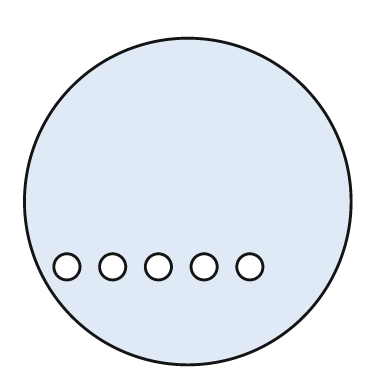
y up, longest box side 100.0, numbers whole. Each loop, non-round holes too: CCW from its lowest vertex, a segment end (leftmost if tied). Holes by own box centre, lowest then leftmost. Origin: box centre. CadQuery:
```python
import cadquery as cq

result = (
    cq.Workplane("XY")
    .moveTo(0.0, 0.0)
    .circle(50.0)
    .moveTo(-37.0, -20.0)
    .circle(4.0)
    .moveTo(-23.0, -20.0)
    .circle(4.0)
    .moveTo(-9.0, -20.0)
    .circle(4.0)
    .moveTo(5.0, -20.0)
    .circle(4.0)
    .moveTo(19.0, -20.0)
    .circle(4.0)
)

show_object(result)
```